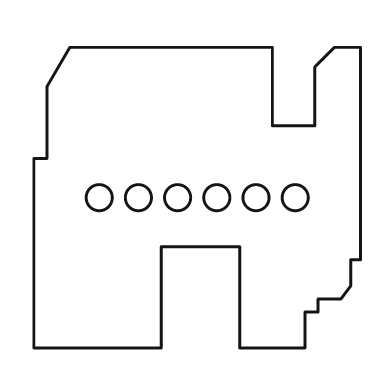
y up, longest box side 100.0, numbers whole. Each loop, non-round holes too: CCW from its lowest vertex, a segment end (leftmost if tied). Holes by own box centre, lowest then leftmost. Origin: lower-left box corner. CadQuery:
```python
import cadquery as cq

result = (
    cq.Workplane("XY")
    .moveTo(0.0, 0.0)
    .lineTo(39.0, 0.0)
    .lineTo(39.0, 31.0)
    .lineTo(63.0, 31.0)
    .lineTo(63.0, 0.0)
    .lineTo(83.0, 0.0)
    .lineTo(83.0, 11.0)
    .lineTo(87.0, 11.0)
    .lineTo(87.0, 15.0)
    .lineTo(94.0, 15.0)
    .lineTo(97.0, 19.0)
    .lineTo(97.0, 27.0)
    .lineTo(100.0, 27.0)
    .lineTo(100.0, 92.0)
    .lineTo(92.0, 92.0)
    .lineTo(86.0, 86.0)
    .lineTo(86.0, 68.0)
    .lineTo(73.0, 68.0)
    .lineTo(73.0, 92.0)
    .lineTo(11.0, 92.0)
    .lineTo(4.0, 80.0)
    .lineTo(4.0, 58.0)
    .lineTo(0.0, 58.0)
    .close()
    .moveTo(20.0, 46.0)
    .circle(4.0)
    .moveTo(32.0, 46.0)
    .circle(4.0)
    .moveTo(44.0, 46.0)
    .circle(4.0)
    .moveTo(56.0, 46.0)
    .circle(4.0)
    .moveTo(68.0, 46.0)
    .circle(4.0)
    .moveTo(80.0, 46.0)
    .circle(4.0)
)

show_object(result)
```